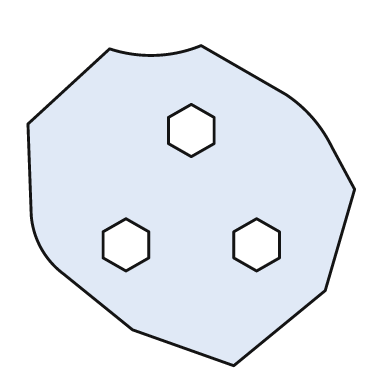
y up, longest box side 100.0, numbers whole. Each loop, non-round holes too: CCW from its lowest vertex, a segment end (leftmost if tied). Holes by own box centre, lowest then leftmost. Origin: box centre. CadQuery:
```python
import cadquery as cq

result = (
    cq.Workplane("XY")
    .moveTo(13.0, -49.0)
    .lineTo(41.0, -26.0)
    .lineTo(50.0, 5.0)
    .lineTo(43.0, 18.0)
    .threePointArc((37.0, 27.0), (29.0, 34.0))
    .lineTo(3.0, 49.0)
    .threePointArc((-11.0, 46.0), (-25.0, 48.0))
    .lineTo(-50.0, 25.0)
    .lineTo(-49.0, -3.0)
    .threePointArc((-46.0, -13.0), (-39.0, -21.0))
    .lineTo(-18.0, -38.0)
    .close()
    .moveTo(-20.0, -20.0)
    .lineTo(-13.0, -16.0)
    .lineTo(-13.0, -8.0)
    .lineTo(-20.0, -4.0)
    .lineTo(-27.0, -8.0)
    .lineTo(-27.0, -16.0)
    .close()
    .moveTo(20.0, -20.0)
    .lineTo(27.0, -16.0)
    .lineTo(27.0, -8.0)
    .lineTo(20.0, -4.0)
    .lineTo(13.0, -8.0)
    .lineTo(13.0, -16.0)
    .close()
    .moveTo(0.0, 15.0)
    .lineTo(7.0, 19.0)
    .lineTo(7.0, 27.0)
    .lineTo(0.0, 31.0)
    .lineTo(-7.0, 27.0)
    .lineTo(-7.0, 19.0)
    .close()
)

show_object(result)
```